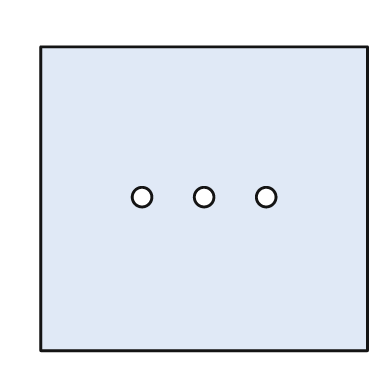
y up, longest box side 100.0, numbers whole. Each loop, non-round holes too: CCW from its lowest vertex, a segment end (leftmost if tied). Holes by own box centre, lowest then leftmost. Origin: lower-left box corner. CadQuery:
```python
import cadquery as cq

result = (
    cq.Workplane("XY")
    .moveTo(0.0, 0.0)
    .lineTo(100.0, 0.0)
    .lineTo(100.0, 93.0)
    .lineTo(0.0, 93.0)
    .close()
    .moveTo(31.0, 47.0)
    .circle(3.0)
    .moveTo(50.0, 47.0)
    .circle(3.0)
    .moveTo(69.0, 47.0)
    .circle(3.0)
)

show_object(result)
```